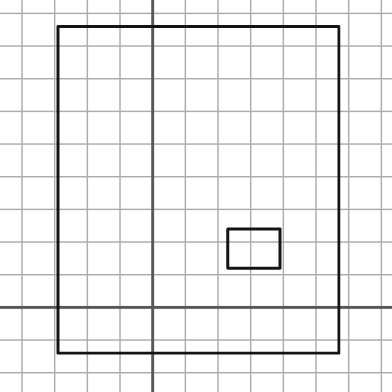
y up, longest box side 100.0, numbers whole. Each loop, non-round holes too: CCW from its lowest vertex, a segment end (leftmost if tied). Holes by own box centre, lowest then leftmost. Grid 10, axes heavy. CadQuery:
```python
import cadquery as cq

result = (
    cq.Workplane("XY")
    .moveTo(-29.0, -14.0)
    .lineTo(57.0, -14.0)
    .lineTo(57.0, 86.0)
    .lineTo(-29.0, 86.0)
    .close()
    .moveTo(23.0, 12.0)
    .lineTo(39.0, 12.0)
    .lineTo(39.0, 24.0)
    .lineTo(23.0, 24.0)
    .close()
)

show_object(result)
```